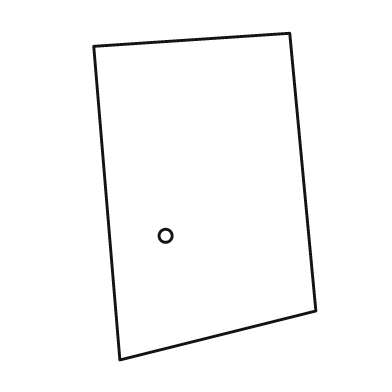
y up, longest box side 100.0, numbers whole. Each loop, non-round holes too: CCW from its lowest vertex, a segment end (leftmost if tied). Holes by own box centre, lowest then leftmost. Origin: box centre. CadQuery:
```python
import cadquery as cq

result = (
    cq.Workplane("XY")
    .moveTo(-26.0, -50.0)
    .lineTo(34.0, -35.0)
    .lineTo(26.0, 50.0)
    .lineTo(-34.0, 46.0)
    .close()
    .moveTo(-12.0, -12.0)
    .circle(2.0)
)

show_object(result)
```